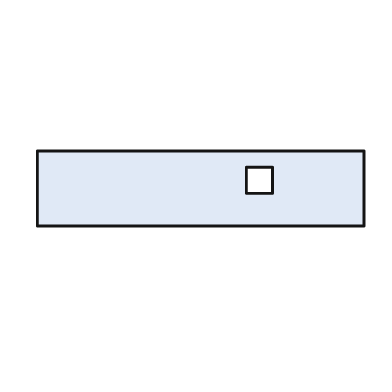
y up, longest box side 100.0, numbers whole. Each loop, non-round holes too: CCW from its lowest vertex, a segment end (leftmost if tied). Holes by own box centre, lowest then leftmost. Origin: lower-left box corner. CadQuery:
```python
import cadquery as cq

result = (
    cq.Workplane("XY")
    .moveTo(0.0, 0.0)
    .lineTo(100.0, 0.0)
    .lineTo(100.0, 23.0)
    .lineTo(0.0, 23.0)
    .close()
    .moveTo(64.0, 10.0)
    .lineTo(72.0, 10.0)
    .lineTo(72.0, 18.0)
    .lineTo(64.0, 18.0)
    .close()
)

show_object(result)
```